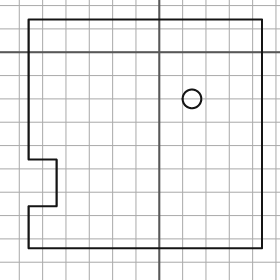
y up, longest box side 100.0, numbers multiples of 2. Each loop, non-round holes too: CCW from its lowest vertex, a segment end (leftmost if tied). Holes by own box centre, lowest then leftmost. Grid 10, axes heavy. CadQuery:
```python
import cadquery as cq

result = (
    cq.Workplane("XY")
    .moveTo(-56.0, -84.0)
    .lineTo(44.0, -84.0)
    .lineTo(44.0, 14.0)
    .lineTo(-56.0, 14.0)
    .lineTo(-56.0, -46.0)
    .lineTo(-44.0, -46.0)
    .lineTo(-44.0, -66.0)
    .lineTo(-56.0, -66.0)
    .close()
    .moveTo(14.0, -20.0)
    .circle(4.0)
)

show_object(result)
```